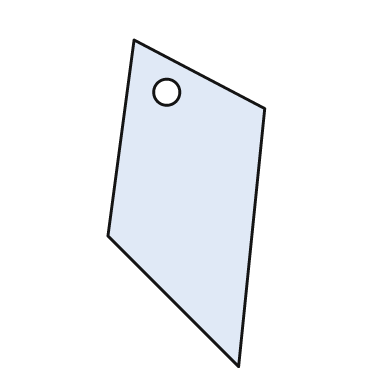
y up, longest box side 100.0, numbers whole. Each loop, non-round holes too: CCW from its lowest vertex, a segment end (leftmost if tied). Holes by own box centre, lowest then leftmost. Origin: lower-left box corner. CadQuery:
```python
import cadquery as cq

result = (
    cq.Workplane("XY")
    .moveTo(40.0, 0.0)
    .lineTo(48.0, 79.0)
    .lineTo(8.0, 100.0)
    .lineTo(0.0, 40.0)
    .close()
    .moveTo(18.0, 84.0)
    .circle(4.0)
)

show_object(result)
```